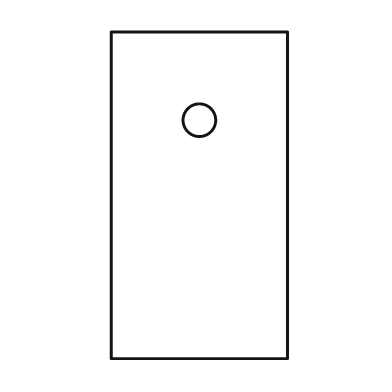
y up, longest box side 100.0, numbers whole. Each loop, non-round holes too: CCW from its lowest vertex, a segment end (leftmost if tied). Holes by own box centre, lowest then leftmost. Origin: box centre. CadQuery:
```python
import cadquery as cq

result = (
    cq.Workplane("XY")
    .moveTo(-27.0, -50.0)
    .lineTo(27.0, -50.0)
    .lineTo(27.0, 50.0)
    .lineTo(-27.0, 50.0)
    .close()
    .moveTo(0.0, 23.0)
    .circle(5.0)
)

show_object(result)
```